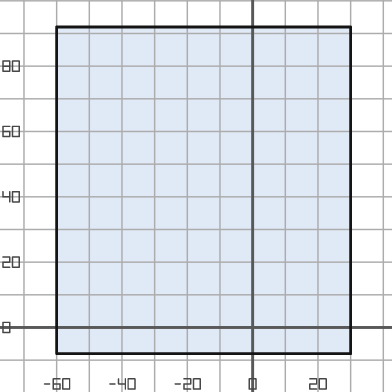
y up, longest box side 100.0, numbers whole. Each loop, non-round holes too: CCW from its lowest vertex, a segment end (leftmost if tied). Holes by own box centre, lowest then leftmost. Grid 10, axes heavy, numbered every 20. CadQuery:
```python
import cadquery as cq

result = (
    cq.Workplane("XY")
    .moveTo(-60.0, -8.0)
    .lineTo(30.0, -8.0)
    .lineTo(30.0, 92.0)
    .lineTo(-60.0, 92.0)
    .close()
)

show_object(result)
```